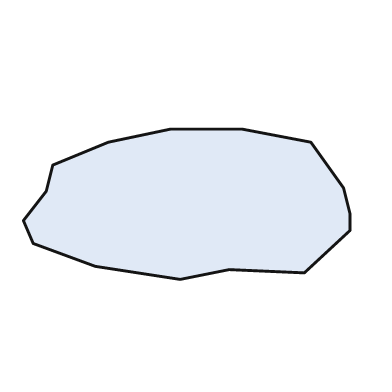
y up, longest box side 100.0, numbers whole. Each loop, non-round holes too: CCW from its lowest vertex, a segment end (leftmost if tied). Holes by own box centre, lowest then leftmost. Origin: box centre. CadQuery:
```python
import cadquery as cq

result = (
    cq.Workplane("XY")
    .moveTo(-2.0, -23.0)
    .lineTo(13.0, -20.0)
    .lineTo(36.0, -21.0)
    .lineTo(50.0, -8.0)
    .lineTo(50.0, -3.0)
    .lineTo(48.0, 5.0)
    .lineTo(38.0, 19.0)
    .lineTo(17.0, 23.0)
    .lineTo(-5.0, 23.0)
    .lineTo(-24.0, 19.0)
    .lineTo(-41.0, 12.0)
    .lineTo(-43.0, 4.0)
    .lineTo(-50.0, -5.0)
    .lineTo(-47.0, -12.0)
    .lineTo(-28.0, -19.0)
    .close()
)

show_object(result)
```